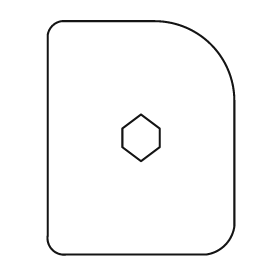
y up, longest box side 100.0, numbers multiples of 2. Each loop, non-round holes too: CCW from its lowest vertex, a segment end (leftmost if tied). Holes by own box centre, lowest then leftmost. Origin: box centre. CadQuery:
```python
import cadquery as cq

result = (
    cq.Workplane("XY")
    .moveTo(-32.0, -50.0)
    .lineTo(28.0, -50.0)
    .threePointArc((36.0, -46.0), (40.0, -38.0))
    .lineTo(40.0, 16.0)
    .threePointArc((30.0, 40.0), (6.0, 50.0))
    .lineTo(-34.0, 50.0)
    .threePointArc((-38.0, 48.0), (-40.0, 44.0))
    .lineTo(-40.0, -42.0)
    .threePointArc((-38.0, -48.0), (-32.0, -50.0))
    .close()
    .moveTo(0.0, -10.0)
    .lineTo(8.0, -4.0)
    .lineTo(8.0, 4.0)
    .lineTo(0.0, 10.0)
    .lineTo(-8.0, 4.0)
    .lineTo(-8.0, -4.0)
    .close()
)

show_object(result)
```